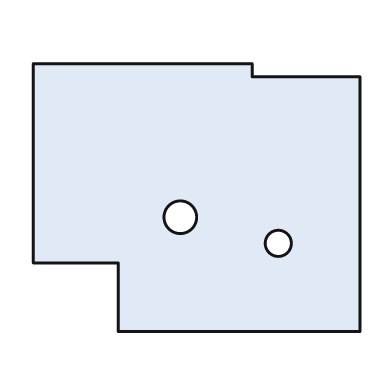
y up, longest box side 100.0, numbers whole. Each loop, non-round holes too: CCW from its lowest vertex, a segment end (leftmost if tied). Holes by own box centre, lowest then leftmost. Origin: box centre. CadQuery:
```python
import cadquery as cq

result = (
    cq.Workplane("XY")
    .moveTo(-24.0, -41.0)
    .lineTo(50.0, -41.0)
    .lineTo(50.0, 37.0)
    .lineTo(17.0, 37.0)
    .lineTo(17.0, 41.0)
    .lineTo(-50.0, 41.0)
    .lineTo(-50.0, -20.0)
    .lineTo(-24.0, -20.0)
    .close()
    .moveTo(25.0, -14.0)
    .circle(4.0)
    .moveTo(-5.0, -6.0)
    .circle(5.0)
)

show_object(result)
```